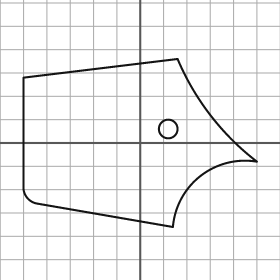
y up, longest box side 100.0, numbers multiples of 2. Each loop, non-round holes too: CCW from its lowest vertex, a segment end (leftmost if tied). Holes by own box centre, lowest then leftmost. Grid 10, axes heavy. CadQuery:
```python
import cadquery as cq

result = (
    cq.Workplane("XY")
    .moveTo(14.0, -36.0)
    .threePointArc((26.0, -14.0), (50.0, -8.0))
    .threePointArc((30.0, 12.0), (16.0, 36.0))
    .lineTo(-50.0, 28.0)
    .lineTo(-50.0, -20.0)
    .threePointArc((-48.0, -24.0), (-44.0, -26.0))
    .close()
    .moveTo(12.0, 6.0)
    .circle(4.0)
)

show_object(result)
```